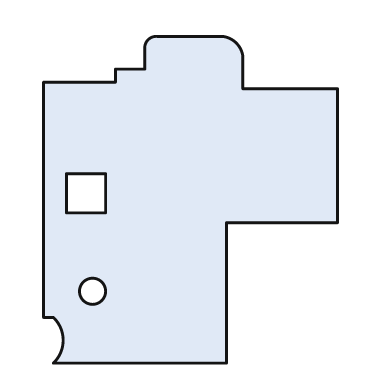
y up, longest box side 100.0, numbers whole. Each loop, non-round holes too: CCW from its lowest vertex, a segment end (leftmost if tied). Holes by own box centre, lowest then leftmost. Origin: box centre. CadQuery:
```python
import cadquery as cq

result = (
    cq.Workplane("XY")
    .moveTo(-42.0, -50.0)
    .lineTo(11.0, -50.0)
    .lineTo(11.0, -7.0)
    .lineTo(45.0, -7.0)
    .lineTo(45.0, 34.0)
    .lineTo(16.0, 34.0)
    .lineTo(16.0, 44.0)
    .threePointArc((14.0, 48.0), (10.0, 50.0))
    .lineTo(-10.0, 50.0)
    .threePointArc((-13.0, 49.0), (-14.0, 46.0))
    .lineTo(-14.0, 40.0)
    .lineTo(-23.0, 40.0)
    .lineTo(-23.0, 36.0)
    .lineTo(-45.0, 36.0)
    .lineTo(-45.0, -36.0)
    .lineTo(-42.0, -36.0)
    .threePointArc((-39.0, -43.0), (-42.0, -50.0))
    .close()
    .moveTo(-30.0, -28.0)
    .circle(4.0)
    .moveTo(-38.0, -4.0)
    .lineTo(-26.0, -4.0)
    .lineTo(-26.0, 8.0)
    .lineTo(-38.0, 8.0)
    .close()
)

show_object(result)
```